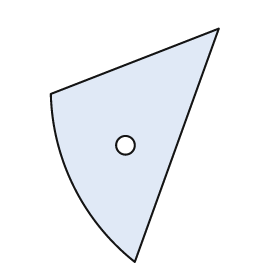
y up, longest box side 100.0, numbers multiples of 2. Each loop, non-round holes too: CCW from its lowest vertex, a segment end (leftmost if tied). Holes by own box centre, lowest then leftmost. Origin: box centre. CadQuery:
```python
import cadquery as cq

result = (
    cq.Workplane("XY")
    .moveTo(0.0, -50.0)
    .lineTo(36.0, 50.0)
    .lineTo(-36.0, 22.0)
    .threePointArc((-26.0, -18.0), (0.0, -50.0))
    .close()
    .moveTo(-4.0, 0.0)
    .circle(4.0)
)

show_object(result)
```